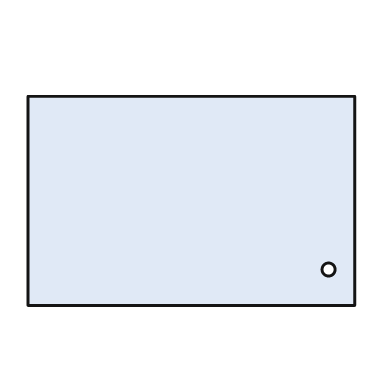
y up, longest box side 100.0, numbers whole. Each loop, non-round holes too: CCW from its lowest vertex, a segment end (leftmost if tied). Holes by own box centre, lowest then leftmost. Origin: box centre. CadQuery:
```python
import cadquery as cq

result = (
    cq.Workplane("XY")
    .moveTo(-50.0, -32.0)
    .lineTo(50.0, -32.0)
    .lineTo(50.0, 32.0)
    .lineTo(-50.0, 32.0)
    .close()
    .moveTo(42.0, -21.0)
    .circle(2.0)
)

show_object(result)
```